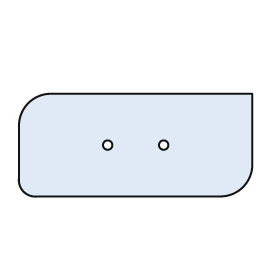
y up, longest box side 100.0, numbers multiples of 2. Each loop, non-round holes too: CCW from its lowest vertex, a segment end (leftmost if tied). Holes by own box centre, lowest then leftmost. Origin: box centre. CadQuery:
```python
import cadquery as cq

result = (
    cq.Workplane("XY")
    .moveTo(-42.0, -22.0)
    .lineTo(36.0, -22.0)
    .threePointArc((46.0, -18.0), (50.0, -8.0))
    .lineTo(50.0, 22.0)
    .lineTo(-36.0, 22.0)
    .threePointArc((-46.0, 18.0), (-50.0, 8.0))
    .lineTo(-50.0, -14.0)
    .threePointArc((-48.0, -20.0), (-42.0, -22.0))
    .close()
    .moveTo(-12.0, 0.0)
    .circle(2.0)
    .moveTo(12.0, 0.0)
    .circle(2.0)
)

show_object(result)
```